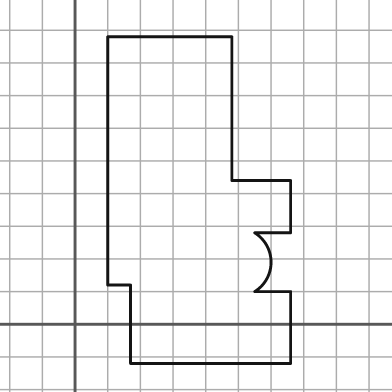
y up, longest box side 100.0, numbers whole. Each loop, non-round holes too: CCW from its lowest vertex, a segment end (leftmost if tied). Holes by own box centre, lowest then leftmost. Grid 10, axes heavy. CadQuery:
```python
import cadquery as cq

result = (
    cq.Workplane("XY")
    .moveTo(17.0, -12.0)
    .lineTo(66.0, -12.0)
    .lineTo(66.0, 10.0)
    .lineTo(55.0, 10.0)
    .threePointArc((60.0, 19.0), (55.0, 28.0))
    .lineTo(66.0, 28.0)
    .lineTo(66.0, 44.0)
    .lineTo(48.0, 44.0)
    .lineTo(48.0, 88.0)
    .lineTo(10.0, 88.0)
    .lineTo(10.0, 12.0)
    .lineTo(17.0, 12.0)
    .close()
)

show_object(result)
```